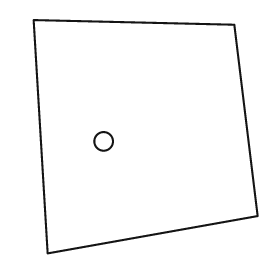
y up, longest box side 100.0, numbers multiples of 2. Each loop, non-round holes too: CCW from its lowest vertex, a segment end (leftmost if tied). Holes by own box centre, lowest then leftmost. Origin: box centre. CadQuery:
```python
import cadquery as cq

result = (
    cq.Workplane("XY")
    .moveTo(-42.0, -50.0)
    .lineTo(48.0, -34.0)
    .lineTo(38.0, 48.0)
    .lineTo(-48.0, 50.0)
    .close()
    .moveTo(-18.0, -2.0)
    .circle(4.0)
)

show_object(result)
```